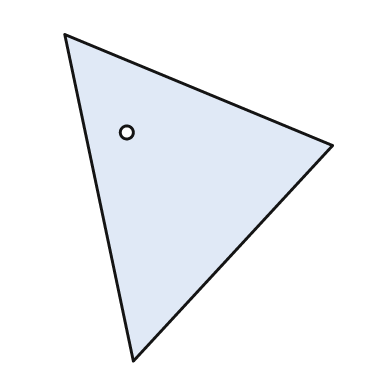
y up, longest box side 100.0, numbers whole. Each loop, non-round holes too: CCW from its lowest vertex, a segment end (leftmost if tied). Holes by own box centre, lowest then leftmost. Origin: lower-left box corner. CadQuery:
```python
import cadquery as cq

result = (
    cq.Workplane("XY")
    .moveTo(21.0, 0.0)
    .lineTo(82.0, 66.0)
    .lineTo(0.0, 100.0)
    .close()
    .moveTo(19.0, 70.0)
    .circle(2.0)
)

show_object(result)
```